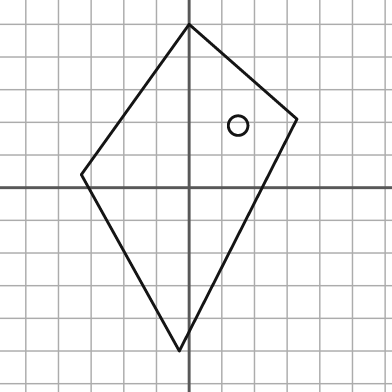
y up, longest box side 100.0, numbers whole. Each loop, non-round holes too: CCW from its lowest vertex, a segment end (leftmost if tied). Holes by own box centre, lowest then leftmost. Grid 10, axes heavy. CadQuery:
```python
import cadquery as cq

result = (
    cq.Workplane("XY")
    .moveTo(-3.0, -50.0)
    .lineTo(33.0, 21.0)
    .lineTo(0.0, 50.0)
    .lineTo(-33.0, 4.0)
    .close()
    .moveTo(15.0, 19.0)
    .circle(3.0)
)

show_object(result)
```